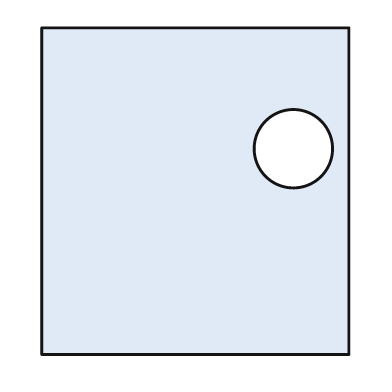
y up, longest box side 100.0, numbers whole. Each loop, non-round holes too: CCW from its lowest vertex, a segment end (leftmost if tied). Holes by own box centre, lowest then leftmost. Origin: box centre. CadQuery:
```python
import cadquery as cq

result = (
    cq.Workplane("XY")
    .moveTo(-47.0, -50.0)
    .lineTo(47.0, -50.0)
    .lineTo(47.0, 50.0)
    .lineTo(-47.0, 50.0)
    .close()
    .moveTo(30.0, 13.0)
    .circle(12.0)
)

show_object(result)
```